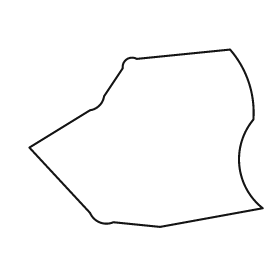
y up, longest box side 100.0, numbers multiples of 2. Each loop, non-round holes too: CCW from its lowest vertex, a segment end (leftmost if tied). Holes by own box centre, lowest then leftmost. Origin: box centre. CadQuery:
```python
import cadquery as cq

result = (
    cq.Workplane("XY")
    .moveTo(6.0, -38.0)
    .lineTo(50.0, -30.0)
    .threePointArc((40.0, -12.0), (46.0, 8.0))
    .threePointArc((44.0, 24.0), (36.0, 38.0))
    .lineTo(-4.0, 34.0)
    .threePointArc((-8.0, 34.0), (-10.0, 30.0))
    .lineTo(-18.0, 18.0)
    .threePointArc((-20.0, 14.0), (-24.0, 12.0))
    .lineTo(-50.0, -4.0)
    .lineTo(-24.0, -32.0)
    .threePointArc((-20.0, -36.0), (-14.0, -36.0))
    .close()
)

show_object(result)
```